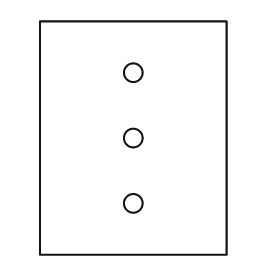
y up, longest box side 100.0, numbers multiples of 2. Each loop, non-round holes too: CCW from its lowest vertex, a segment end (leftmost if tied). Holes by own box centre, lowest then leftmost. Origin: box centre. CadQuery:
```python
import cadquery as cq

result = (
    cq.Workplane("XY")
    .moveTo(-40.0, -50.0)
    .lineTo(40.0, -50.0)
    .lineTo(40.0, 50.0)
    .lineTo(-40.0, 50.0)
    .close()
    .moveTo(0.0, -28.0)
    .circle(4.0)
    .moveTo(0.0, 0.0)
    .circle(4.0)
    .moveTo(0.0, 28.0)
    .circle(4.0)
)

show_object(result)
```